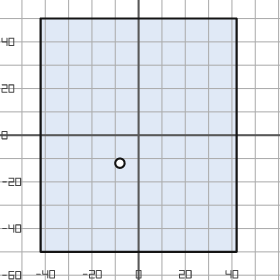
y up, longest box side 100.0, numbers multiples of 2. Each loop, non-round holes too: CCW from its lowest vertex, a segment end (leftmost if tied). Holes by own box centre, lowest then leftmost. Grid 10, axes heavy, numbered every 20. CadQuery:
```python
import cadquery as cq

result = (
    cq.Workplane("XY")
    .moveTo(-42.0, -50.0)
    .lineTo(42.0, -50.0)
    .lineTo(42.0, 50.0)
    .lineTo(-42.0, 50.0)
    .close()
    .moveTo(-8.0, -12.0)
    .circle(2.0)
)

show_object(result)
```